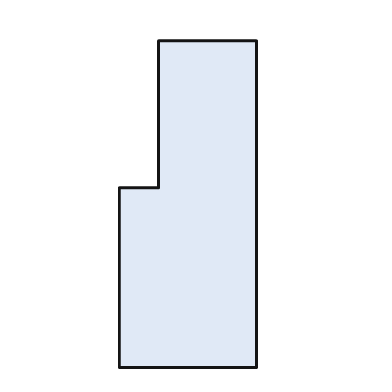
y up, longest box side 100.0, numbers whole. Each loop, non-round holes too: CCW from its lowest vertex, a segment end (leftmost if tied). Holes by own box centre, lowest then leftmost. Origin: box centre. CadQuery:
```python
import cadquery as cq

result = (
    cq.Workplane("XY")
    .moveTo(-21.0, -50.0)
    .lineTo(21.0, -50.0)
    .lineTo(21.0, 50.0)
    .lineTo(-9.0, 50.0)
    .lineTo(-9.0, 5.0)
    .lineTo(-21.0, 5.0)
    .close()
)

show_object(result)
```